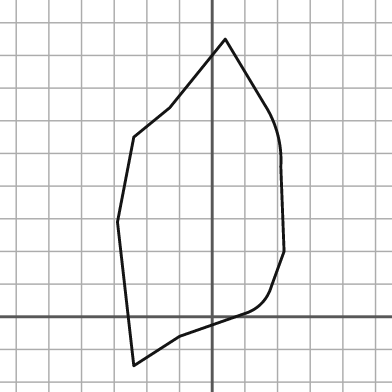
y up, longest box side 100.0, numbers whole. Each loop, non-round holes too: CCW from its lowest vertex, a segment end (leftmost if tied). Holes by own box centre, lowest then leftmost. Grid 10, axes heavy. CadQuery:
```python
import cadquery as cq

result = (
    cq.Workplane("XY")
    .moveTo(-24.0, -15.0)
    .lineTo(-10.0, -6.0)
    .lineTo(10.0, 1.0)
    .threePointArc((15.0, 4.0), (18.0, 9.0))
    .lineTo(22.0, 20.0)
    .lineTo(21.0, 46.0)
    .threePointArc((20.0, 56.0), (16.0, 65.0))
    .lineTo(4.0, 85.0)
    .lineTo(-13.0, 64.0)
    .lineTo(-24.0, 55.0)
    .lineTo(-29.0, 29.0)
    .close()
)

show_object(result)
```